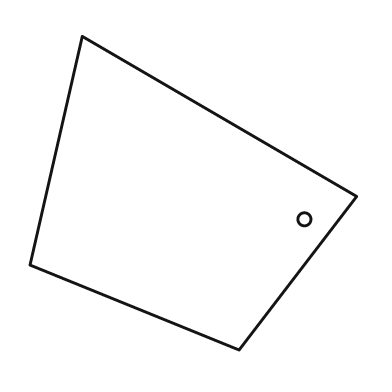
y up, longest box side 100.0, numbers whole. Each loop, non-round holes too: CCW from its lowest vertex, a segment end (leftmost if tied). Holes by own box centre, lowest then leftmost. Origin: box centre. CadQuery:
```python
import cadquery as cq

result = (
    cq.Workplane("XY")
    .moveTo(14.0, -48.0)
    .lineTo(50.0, -1.0)
    .lineTo(-34.0, 48.0)
    .lineTo(-50.0, -22.0)
    .close()
    .moveTo(34.0, -8.0)
    .circle(2.0)
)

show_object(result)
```